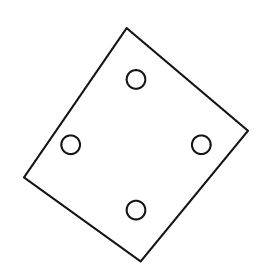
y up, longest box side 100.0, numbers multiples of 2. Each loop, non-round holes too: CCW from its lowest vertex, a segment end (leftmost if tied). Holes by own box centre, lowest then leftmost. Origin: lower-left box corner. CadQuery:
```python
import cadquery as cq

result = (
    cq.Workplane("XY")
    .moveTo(50.0, 0.0)
    .lineTo(96.0, 56.0)
    .lineTo(44.0, 100.0)
    .lineTo(0.0, 36.0)
    .close()
    .moveTo(48.0, 22.0)
    .circle(4.0)
    .moveTo(20.0, 50.0)
    .circle(4.0)
    .moveTo(76.0, 50.0)
    .circle(4.0)
    .moveTo(48.0, 78.0)
    .circle(4.0)
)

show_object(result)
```